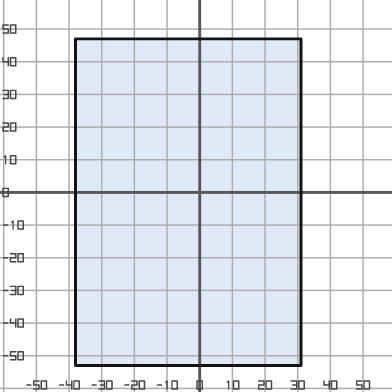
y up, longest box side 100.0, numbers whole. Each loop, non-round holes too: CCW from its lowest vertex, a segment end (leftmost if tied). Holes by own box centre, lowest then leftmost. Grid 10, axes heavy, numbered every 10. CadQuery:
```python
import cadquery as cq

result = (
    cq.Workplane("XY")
    .moveTo(-38.0, -53.0)
    .lineTo(31.0, -53.0)
    .lineTo(31.0, 47.0)
    .lineTo(-38.0, 47.0)
    .close()
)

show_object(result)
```